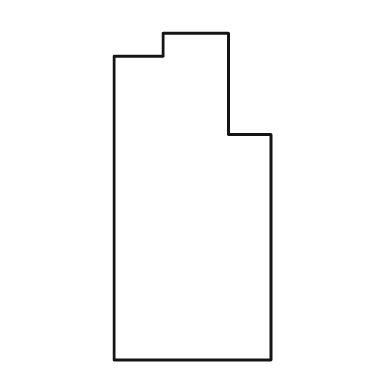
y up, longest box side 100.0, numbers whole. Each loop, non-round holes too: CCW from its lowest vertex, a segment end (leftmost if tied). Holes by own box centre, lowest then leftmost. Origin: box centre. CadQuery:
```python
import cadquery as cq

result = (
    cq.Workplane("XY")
    .moveTo(-24.0, -50.0)
    .lineTo(24.0, -50.0)
    .lineTo(24.0, 19.0)
    .lineTo(11.0, 19.0)
    .lineTo(11.0, 50.0)
    .lineTo(-9.0, 50.0)
    .lineTo(-9.0, 43.0)
    .lineTo(-24.0, 43.0)
    .close()
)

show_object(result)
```